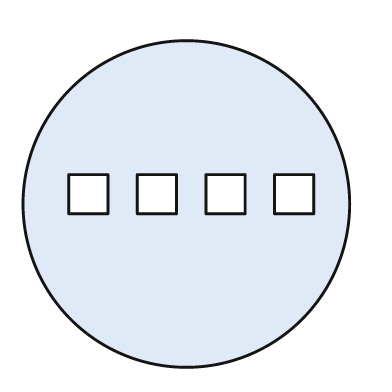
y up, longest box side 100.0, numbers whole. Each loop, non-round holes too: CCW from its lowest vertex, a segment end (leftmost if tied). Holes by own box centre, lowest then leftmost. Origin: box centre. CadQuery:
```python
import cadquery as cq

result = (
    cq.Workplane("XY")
    .moveTo(0.0, 0.0)
    .circle(50.0)
    .moveTo(-36.0, -3.0)
    .lineTo(-24.0, -3.0)
    .lineTo(-24.0, 9.0)
    .lineTo(-36.0, 9.0)
    .close()
    .moveTo(-15.0, -3.0)
    .lineTo(-3.0, -3.0)
    .lineTo(-3.0, 9.0)
    .lineTo(-15.0, 9.0)
    .close()
    .moveTo(6.0, -3.0)
    .lineTo(18.0, -3.0)
    .lineTo(18.0, 9.0)
    .lineTo(6.0, 9.0)
    .close()
    .moveTo(27.0, -3.0)
    .lineTo(39.0, -3.0)
    .lineTo(39.0, 9.0)
    .lineTo(27.0, 9.0)
    .close()
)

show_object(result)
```